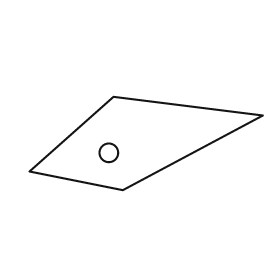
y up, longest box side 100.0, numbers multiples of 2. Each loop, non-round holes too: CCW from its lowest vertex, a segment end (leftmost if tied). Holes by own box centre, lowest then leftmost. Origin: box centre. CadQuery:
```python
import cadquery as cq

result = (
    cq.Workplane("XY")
    .moveTo(-10.0, -20.0)
    .lineTo(50.0, 12.0)
    .lineTo(-14.0, 20.0)
    .lineTo(-50.0, -12.0)
    .close()
    .moveTo(-16.0, -4.0)
    .circle(4.0)
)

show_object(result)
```